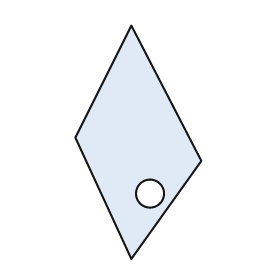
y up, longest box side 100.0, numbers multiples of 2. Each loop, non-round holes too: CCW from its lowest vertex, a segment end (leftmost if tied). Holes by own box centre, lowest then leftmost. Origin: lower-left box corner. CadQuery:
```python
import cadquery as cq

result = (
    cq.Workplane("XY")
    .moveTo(24.0, 0.0)
    .lineTo(54.0, 42.0)
    .lineTo(24.0, 100.0)
    .lineTo(0.0, 52.0)
    .close()
    .moveTo(32.0, 28.0)
    .circle(6.0)
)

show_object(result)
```